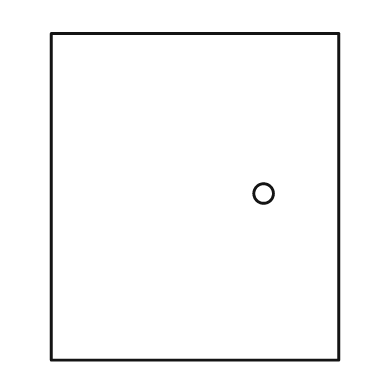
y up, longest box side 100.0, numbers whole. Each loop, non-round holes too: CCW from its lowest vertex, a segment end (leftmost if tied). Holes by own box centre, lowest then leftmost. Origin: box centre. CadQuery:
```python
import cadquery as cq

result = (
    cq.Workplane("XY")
    .moveTo(-44.0, -50.0)
    .lineTo(44.0, -50.0)
    .lineTo(44.0, 50.0)
    .lineTo(-44.0, 50.0)
    .close()
    .moveTo(21.0, 1.0)
    .circle(3.0)
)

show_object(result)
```